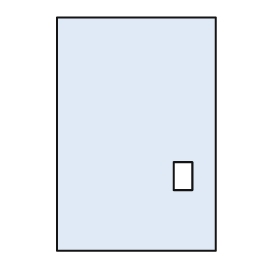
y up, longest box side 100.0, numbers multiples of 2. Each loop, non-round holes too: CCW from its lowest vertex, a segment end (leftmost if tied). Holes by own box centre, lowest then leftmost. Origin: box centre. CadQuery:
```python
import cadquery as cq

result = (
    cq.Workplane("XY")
    .moveTo(-34.0, -50.0)
    .lineTo(34.0, -50.0)
    .lineTo(34.0, 50.0)
    .lineTo(-34.0, 50.0)
    .close()
    .moveTo(16.0, -24.0)
    .lineTo(24.0, -24.0)
    .lineTo(24.0, -12.0)
    .lineTo(16.0, -12.0)
    .close()
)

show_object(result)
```